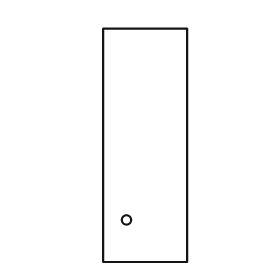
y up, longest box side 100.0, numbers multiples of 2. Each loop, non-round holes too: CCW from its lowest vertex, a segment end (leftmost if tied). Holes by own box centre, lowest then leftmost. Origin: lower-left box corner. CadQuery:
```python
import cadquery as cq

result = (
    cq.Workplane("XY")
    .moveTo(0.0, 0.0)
    .lineTo(36.0, 0.0)
    .lineTo(36.0, 100.0)
    .lineTo(0.0, 100.0)
    .close()
    .moveTo(10.0, 18.0)
    .circle(2.0)
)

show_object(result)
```